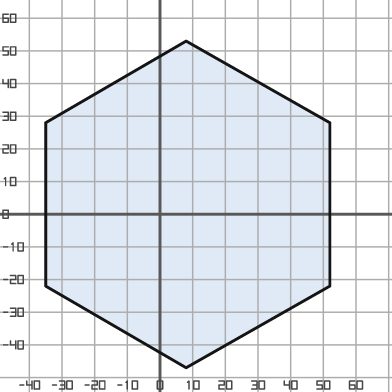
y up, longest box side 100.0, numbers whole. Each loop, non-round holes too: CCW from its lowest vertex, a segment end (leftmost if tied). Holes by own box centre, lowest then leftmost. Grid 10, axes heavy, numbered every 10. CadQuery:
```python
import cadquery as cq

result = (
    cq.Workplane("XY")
    .moveTo(8.0, -47.0)
    .lineTo(52.0, -22.0)
    .lineTo(52.0, 28.0)
    .lineTo(8.0, 53.0)
    .lineTo(-35.0, 28.0)
    .lineTo(-35.0, -22.0)
    .close()
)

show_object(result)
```